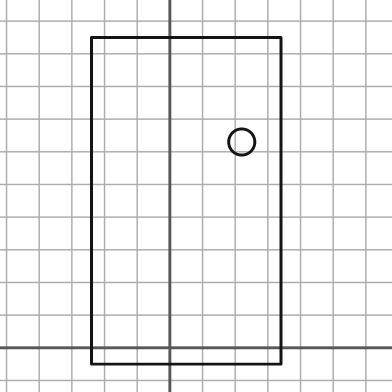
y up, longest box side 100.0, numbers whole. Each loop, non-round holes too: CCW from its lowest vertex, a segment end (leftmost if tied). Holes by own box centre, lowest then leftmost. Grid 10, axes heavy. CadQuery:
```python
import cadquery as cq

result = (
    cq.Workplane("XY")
    .moveTo(-24.0, -5.0)
    .lineTo(34.0, -5.0)
    .lineTo(34.0, 95.0)
    .lineTo(-24.0, 95.0)
    .close()
    .moveTo(22.0, 63.0)
    .circle(4.0)
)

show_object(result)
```